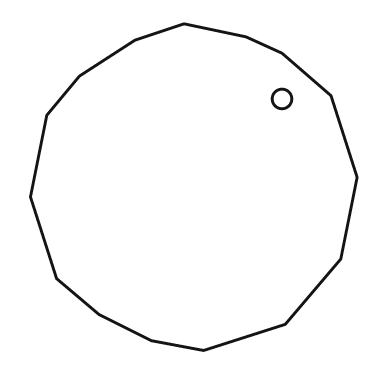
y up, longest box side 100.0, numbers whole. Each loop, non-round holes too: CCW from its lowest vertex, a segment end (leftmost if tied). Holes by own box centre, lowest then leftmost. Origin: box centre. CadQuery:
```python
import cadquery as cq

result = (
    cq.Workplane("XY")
    .moveTo(3.0, -50.0)
    .lineTo(28.0, -42.0)
    .lineTo(45.0, -22.0)
    .lineTo(50.0, 3.0)
    .lineTo(42.0, 28.0)
    .lineTo(27.0, 41.0)
    .lineTo(16.0, 46.0)
    .lineTo(-3.0, 50.0)
    .lineTo(-18.0, 45.0)
    .lineTo(-35.0, 34.0)
    .lineTo(-45.0, 22.0)
    .lineTo(-50.0, -3.0)
    .lineTo(-42.0, -28.0)
    .lineTo(-29.0, -39.0)
    .lineTo(-13.0, -47.0)
    .close()
    .moveTo(27.0, 27.0)
    .circle(3.0)
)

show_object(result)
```